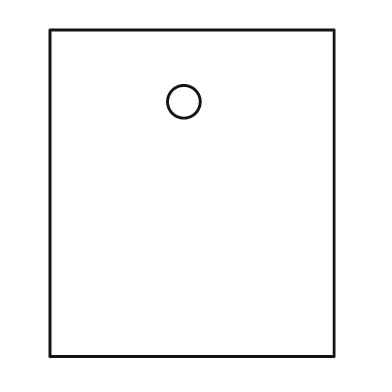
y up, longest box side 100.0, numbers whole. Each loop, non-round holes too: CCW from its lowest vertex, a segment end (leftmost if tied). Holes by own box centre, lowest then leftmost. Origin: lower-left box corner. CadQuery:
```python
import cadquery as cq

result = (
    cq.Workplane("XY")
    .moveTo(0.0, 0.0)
    .lineTo(87.0, 0.0)
    .lineTo(87.0, 100.0)
    .lineTo(0.0, 100.0)
    .close()
    .moveTo(41.0, 78.0)
    .circle(5.0)
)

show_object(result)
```